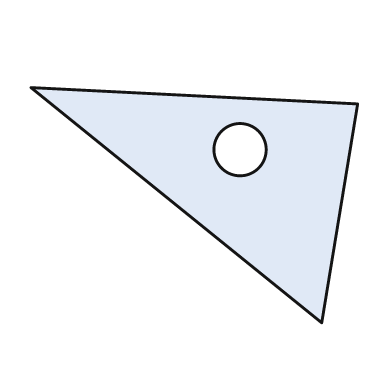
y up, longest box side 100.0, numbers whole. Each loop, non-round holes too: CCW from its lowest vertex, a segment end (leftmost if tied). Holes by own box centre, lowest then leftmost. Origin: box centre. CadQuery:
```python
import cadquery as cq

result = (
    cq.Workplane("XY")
    .moveTo(39.0, -36.0)
    .lineTo(50.0, 31.0)
    .lineTo(-50.0, 36.0)
    .close()
    .moveTo(14.0, 17.0)
    .circle(8.0)
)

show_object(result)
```